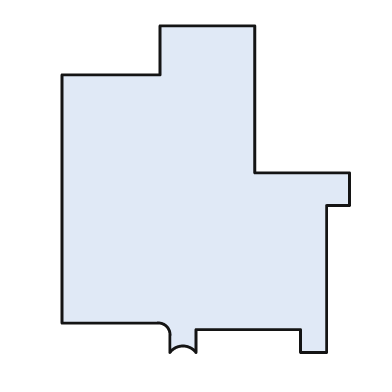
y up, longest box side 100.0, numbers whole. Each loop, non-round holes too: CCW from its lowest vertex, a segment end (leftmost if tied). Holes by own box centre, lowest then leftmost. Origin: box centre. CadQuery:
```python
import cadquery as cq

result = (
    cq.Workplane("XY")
    .moveTo(-11.0, -50.0)
    .threePointArc((-7.0, -48.0), (-3.0, -50.0))
    .lineTo(-3.0, -43.0)
    .lineTo(29.0, -43.0)
    .lineTo(29.0, -50.0)
    .lineTo(37.0, -50.0)
    .lineTo(37.0, -5.0)
    .lineTo(44.0, -5.0)
    .lineTo(44.0, 5.0)
    .lineTo(15.0, 5.0)
    .lineTo(15.0, 50.0)
    .lineTo(-14.0, 50.0)
    .lineTo(-14.0, 35.0)
    .lineTo(-44.0, 35.0)
    .lineTo(-44.0, -41.0)
    .lineTo(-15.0, -41.0)
    .threePointArc((-12.0, -42.0), (-11.0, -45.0))
    .close()
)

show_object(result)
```